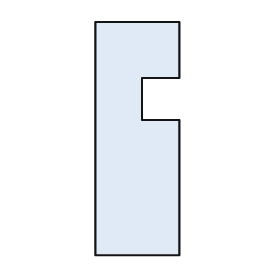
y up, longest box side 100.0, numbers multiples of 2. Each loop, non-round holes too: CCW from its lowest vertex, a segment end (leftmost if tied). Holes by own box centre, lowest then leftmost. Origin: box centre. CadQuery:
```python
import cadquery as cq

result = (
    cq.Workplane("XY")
    .moveTo(-18.0, -50.0)
    .lineTo(18.0, -50.0)
    .lineTo(18.0, 8.0)
    .lineTo(2.0, 8.0)
    .lineTo(2.0, 26.0)
    .lineTo(18.0, 26.0)
    .lineTo(18.0, 50.0)
    .lineTo(-18.0, 50.0)
    .close()
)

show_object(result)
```